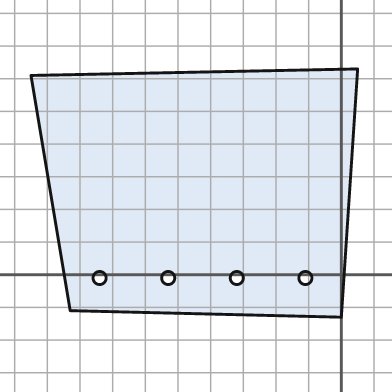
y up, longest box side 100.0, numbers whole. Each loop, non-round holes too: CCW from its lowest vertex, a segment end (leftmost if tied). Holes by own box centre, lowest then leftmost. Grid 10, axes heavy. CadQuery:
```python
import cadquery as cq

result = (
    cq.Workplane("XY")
    .moveTo(0.0, -13.0)
    .lineTo(5.0, 63.0)
    .lineTo(-95.0, 61.0)
    .lineTo(-83.0, -11.0)
    .close()
    .moveTo(-74.0, -1.0)
    .circle(2.0)
    .moveTo(-53.0, -1.0)
    .circle(2.0)
    .moveTo(-32.0, -1.0)
    .circle(2.0)
    .moveTo(-11.0, -1.0)
    .circle(2.0)
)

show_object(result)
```